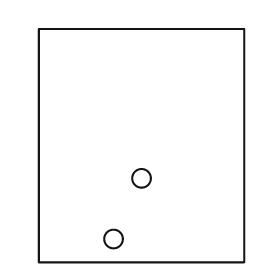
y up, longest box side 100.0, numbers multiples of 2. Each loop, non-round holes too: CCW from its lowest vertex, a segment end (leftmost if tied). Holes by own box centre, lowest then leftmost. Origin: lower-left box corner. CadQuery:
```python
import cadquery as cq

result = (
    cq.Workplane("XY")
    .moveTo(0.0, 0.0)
    .lineTo(88.0, 0.0)
    .lineTo(88.0, 100.0)
    .lineTo(0.0, 100.0)
    .close()
    .moveTo(32.0, 10.0)
    .circle(4.0)
    .moveTo(44.0, 36.0)
    .circle(4.0)
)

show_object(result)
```